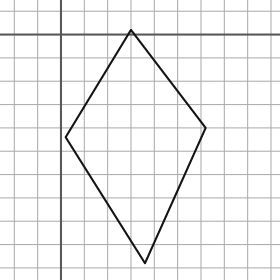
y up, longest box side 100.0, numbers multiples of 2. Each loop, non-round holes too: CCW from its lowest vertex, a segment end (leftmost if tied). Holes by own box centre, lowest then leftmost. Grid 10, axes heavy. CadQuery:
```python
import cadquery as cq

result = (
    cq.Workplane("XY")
    .moveTo(36.0, -98.0)
    .lineTo(62.0, -40.0)
    .lineTo(30.0, 2.0)
    .lineTo(2.0, -44.0)
    .close()
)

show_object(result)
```